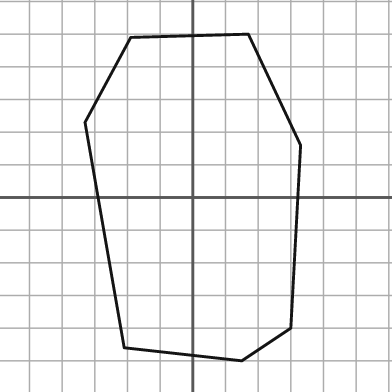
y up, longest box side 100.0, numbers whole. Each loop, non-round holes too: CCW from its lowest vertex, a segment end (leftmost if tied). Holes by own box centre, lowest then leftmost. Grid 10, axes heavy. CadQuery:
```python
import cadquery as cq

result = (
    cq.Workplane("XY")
    .moveTo(15.0, -50.0)
    .lineTo(30.0, -40.0)
    .lineTo(33.0, 16.0)
    .lineTo(17.0, 50.0)
    .lineTo(-19.0, 49.0)
    .lineTo(-33.0, 23.0)
    .lineTo(-21.0, -46.0)
    .close()
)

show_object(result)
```